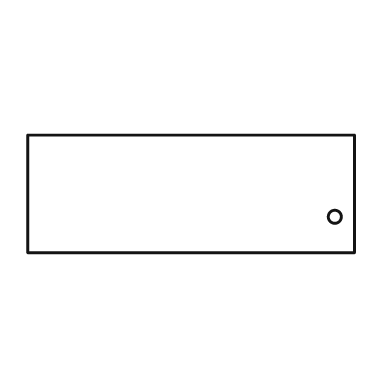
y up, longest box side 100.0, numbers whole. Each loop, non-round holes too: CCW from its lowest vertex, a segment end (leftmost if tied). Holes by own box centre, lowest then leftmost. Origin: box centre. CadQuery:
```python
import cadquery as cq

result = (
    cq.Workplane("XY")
    .moveTo(-50.0, -18.0)
    .lineTo(50.0, -18.0)
    .lineTo(50.0, 18.0)
    .lineTo(-50.0, 18.0)
    .close()
    .moveTo(44.0, -7.0)
    .circle(2.0)
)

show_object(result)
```